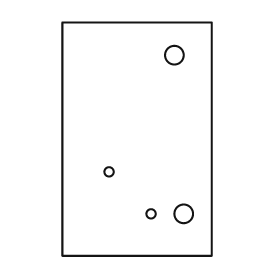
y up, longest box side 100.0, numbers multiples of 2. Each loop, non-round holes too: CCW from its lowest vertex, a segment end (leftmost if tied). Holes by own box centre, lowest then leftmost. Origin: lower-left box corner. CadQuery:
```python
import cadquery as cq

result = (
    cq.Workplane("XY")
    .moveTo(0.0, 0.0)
    .lineTo(64.0, 0.0)
    .lineTo(64.0, 100.0)
    .lineTo(0.0, 100.0)
    .close()
    .moveTo(38.0, 18.0)
    .circle(2.0)
    .moveTo(52.0, 18.0)
    .circle(4.0)
    .moveTo(20.0, 36.0)
    .circle(2.0)
    .moveTo(48.0, 86.0)
    .circle(4.0)
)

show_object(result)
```